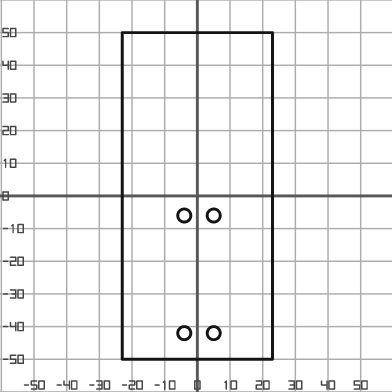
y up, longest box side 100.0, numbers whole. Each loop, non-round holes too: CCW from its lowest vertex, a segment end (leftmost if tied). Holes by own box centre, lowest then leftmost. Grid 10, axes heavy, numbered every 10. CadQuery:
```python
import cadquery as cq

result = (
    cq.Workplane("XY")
    .moveTo(-23.0, -50.0)
    .lineTo(23.0, -50.0)
    .lineTo(23.0, 50.0)
    .lineTo(-23.0, 50.0)
    .close()
    .moveTo(-4.0, -42.0)
    .circle(2.0)
    .moveTo(5.0, -42.0)
    .circle(2.0)
    .moveTo(-4.0, -6.0)
    .circle(2.0)
    .moveTo(5.0, -6.0)
    .circle(2.0)
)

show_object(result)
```